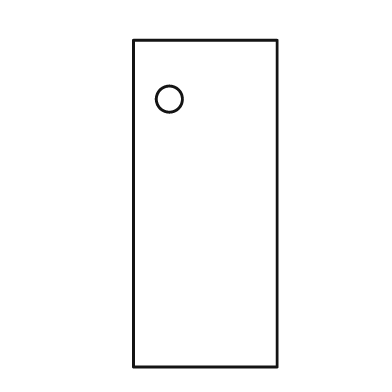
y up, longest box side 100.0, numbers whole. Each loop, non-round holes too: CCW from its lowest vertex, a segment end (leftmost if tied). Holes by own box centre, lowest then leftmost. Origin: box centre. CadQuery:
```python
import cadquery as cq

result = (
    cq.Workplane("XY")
    .moveTo(-22.0, -50.0)
    .lineTo(22.0, -50.0)
    .lineTo(22.0, 50.0)
    .lineTo(-22.0, 50.0)
    .close()
    .moveTo(-11.0, 32.0)
    .circle(4.0)
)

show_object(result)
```